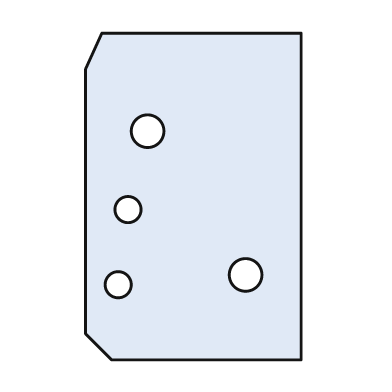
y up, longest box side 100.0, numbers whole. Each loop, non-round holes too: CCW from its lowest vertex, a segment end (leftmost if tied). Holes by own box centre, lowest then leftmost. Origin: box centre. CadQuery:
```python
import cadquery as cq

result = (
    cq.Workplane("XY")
    .moveTo(-25.0, -50.0)
    .lineTo(33.0, -50.0)
    .lineTo(33.0, 50.0)
    .lineTo(-28.0, 50.0)
    .lineTo(-33.0, 39.0)
    .lineTo(-33.0, -42.0)
    .close()
    .moveTo(-23.0, -27.0)
    .circle(4.0)
    .moveTo(16.0, -24.0)
    .circle(5.0)
    .moveTo(-20.0, -4.0)
    .circle(4.0)
    .moveTo(-14.0, 20.0)
    .circle(5.0)
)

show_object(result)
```